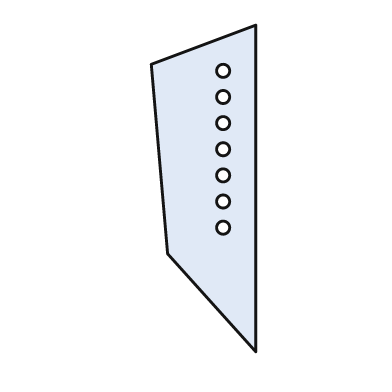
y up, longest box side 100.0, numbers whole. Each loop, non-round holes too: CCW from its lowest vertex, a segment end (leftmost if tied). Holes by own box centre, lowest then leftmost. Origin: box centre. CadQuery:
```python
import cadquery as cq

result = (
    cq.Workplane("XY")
    .moveTo(16.0, -50.0)
    .lineTo(16.0, 50.0)
    .lineTo(-16.0, 38.0)
    .lineTo(-11.0, -20.0)
    .close()
    .moveTo(6.0, -12.0)
    .circle(2.0)
    .moveTo(6.0, -4.0)
    .circle(2.0)
    .moveTo(6.0, 4.0)
    .circle(2.0)
    .moveTo(6.0, 12.0)
    .circle(2.0)
    .moveTo(6.0, 20.0)
    .circle(2.0)
    .moveTo(6.0, 28.0)
    .circle(2.0)
    .moveTo(6.0, 36.0)
    .circle(2.0)
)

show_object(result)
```